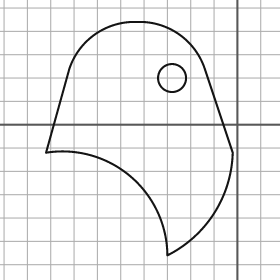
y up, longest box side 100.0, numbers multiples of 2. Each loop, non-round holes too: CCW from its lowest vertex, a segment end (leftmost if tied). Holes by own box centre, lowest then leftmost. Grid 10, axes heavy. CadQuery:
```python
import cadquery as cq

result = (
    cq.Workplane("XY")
    .moveTo(-30.0, -56.0)
    .threePointArc((-10.0, -38.0), (-2.0, -12.0))
    .lineTo(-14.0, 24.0)
    .threePointArc((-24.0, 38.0), (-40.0, 44.0))
    .lineTo(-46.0, 44.0)
    .threePointArc((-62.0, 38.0), (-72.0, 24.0))
    .lineTo(-82.0, -12.0)
    .threePointArc((-46.0, -22.0), (-30.0, -56.0))
    .close()
    .moveTo(-28.0, 20.0)
    .circle(6.0)
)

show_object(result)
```